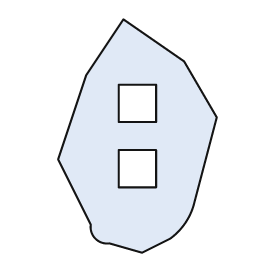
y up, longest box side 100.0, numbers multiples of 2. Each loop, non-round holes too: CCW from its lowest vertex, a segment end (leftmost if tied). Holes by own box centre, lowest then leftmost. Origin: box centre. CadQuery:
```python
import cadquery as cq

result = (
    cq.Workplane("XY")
    .moveTo(2.0, -50.0)
    .lineTo(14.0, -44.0)
    .threePointArc((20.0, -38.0), (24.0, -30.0))
    .lineTo(34.0, 8.0)
    .lineTo(20.0, 32.0)
    .lineTo(-6.0, 50.0)
    .lineTo(-22.0, 26.0)
    .lineTo(-34.0, -10.0)
    .lineTo(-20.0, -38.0)
    .threePointArc((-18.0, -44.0), (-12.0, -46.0))
    .close()
    .moveTo(-8.0, -22.0)
    .lineTo(8.0, -22.0)
    .lineTo(8.0, -6.0)
    .lineTo(-8.0, -6.0)
    .close()
    .moveTo(-8.0, 6.0)
    .lineTo(8.0, 6.0)
    .lineTo(8.0, 22.0)
    .lineTo(-8.0, 22.0)
    .close()
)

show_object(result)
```